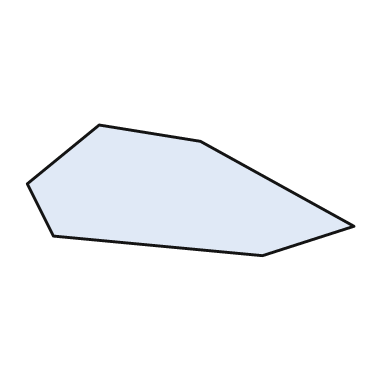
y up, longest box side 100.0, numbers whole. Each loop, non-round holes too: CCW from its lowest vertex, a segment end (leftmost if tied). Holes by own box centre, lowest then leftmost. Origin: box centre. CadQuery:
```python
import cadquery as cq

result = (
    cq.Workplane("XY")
    .moveTo(22.0, -20.0)
    .lineTo(50.0, -11.0)
    .lineTo(3.0, 15.0)
    .lineTo(-28.0, 20.0)
    .lineTo(-50.0, 2.0)
    .lineTo(-42.0, -14.0)
    .close()
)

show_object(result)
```